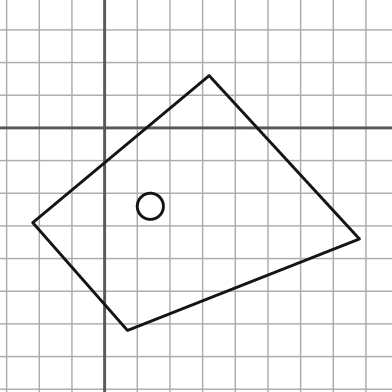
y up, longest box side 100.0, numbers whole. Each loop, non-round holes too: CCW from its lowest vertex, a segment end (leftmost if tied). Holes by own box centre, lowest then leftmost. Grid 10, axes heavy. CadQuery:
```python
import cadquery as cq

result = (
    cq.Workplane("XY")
    .moveTo(7.0, -62.0)
    .lineTo(78.0, -34.0)
    .lineTo(32.0, 16.0)
    .lineTo(-22.0, -29.0)
    .close()
    .moveTo(14.0, -24.0)
    .circle(4.0)
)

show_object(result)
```